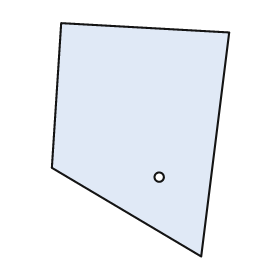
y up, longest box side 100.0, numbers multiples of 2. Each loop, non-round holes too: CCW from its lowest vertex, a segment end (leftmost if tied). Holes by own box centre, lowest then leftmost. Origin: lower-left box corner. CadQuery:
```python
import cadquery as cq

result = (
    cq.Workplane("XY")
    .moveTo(64.0, 0.0)
    .lineTo(76.0, 96.0)
    .lineTo(4.0, 100.0)
    .lineTo(0.0, 38.0)
    .close()
    .moveTo(46.0, 34.0)
    .circle(2.0)
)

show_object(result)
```